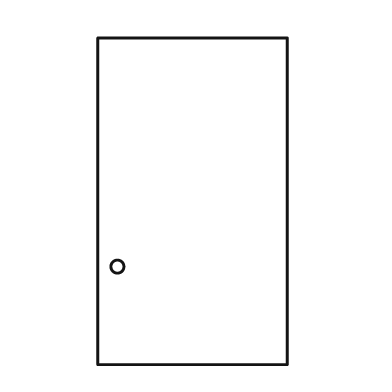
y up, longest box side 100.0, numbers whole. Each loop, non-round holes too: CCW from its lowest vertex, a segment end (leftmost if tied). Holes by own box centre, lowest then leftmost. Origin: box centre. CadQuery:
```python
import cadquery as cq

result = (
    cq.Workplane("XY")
    .moveTo(-29.0, -50.0)
    .lineTo(29.0, -50.0)
    .lineTo(29.0, 50.0)
    .lineTo(-29.0, 50.0)
    .close()
    .moveTo(-23.0, -20.0)
    .circle(2.0)
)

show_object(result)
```